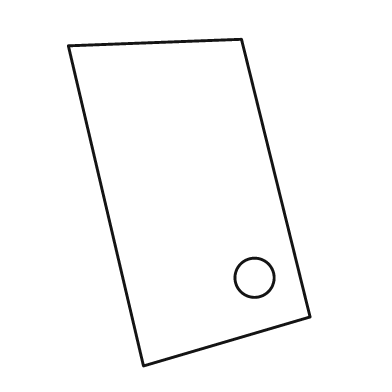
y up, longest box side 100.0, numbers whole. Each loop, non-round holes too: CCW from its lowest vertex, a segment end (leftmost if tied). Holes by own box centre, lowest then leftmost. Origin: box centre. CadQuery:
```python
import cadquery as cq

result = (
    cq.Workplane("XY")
    .moveTo(-14.0, -50.0)
    .lineTo(37.0, -35.0)
    .lineTo(16.0, 50.0)
    .lineTo(-37.0, 48.0)
    .close()
    .moveTo(20.0, -23.0)
    .circle(6.0)
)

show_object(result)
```